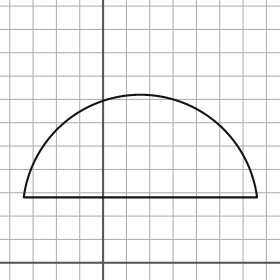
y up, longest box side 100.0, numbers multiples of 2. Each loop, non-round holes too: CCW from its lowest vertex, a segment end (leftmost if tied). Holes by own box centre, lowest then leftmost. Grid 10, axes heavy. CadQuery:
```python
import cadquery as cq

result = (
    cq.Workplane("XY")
    .moveTo(-34.0, 28.0)
    .lineTo(66.0, 28.0)
    .threePointArc((16.0, 72.0), (-34.0, 28.0))
    .close()
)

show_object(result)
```